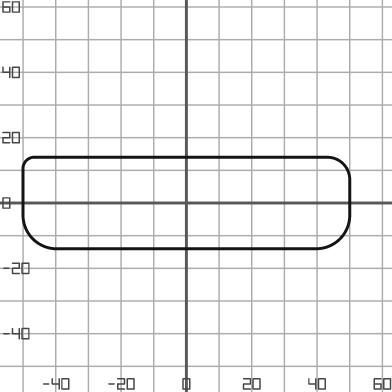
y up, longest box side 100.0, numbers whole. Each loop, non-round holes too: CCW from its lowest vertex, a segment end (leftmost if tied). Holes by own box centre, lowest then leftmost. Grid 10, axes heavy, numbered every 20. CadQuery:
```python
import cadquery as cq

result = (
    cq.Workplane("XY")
    .moveTo(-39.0, -14.0)
    .lineTo(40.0, -14.0)
    .threePointArc((47.0, -11.0), (50.0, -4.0))
    .lineTo(50.0, 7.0)
    .threePointArc((48.0, 12.0), (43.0, 14.0))
    .lineTo(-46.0, 14.0)
    .threePointArc((-49.0, 13.0), (-50.0, 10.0))
    .lineTo(-50.0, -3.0)
    .threePointArc((-47.0, -11.0), (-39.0, -14.0))
    .close()
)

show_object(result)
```